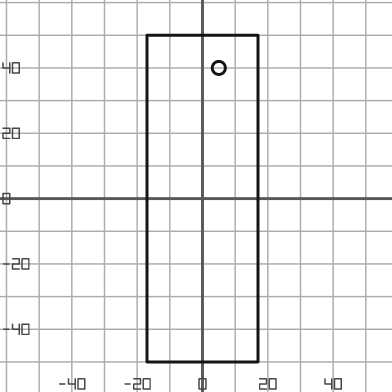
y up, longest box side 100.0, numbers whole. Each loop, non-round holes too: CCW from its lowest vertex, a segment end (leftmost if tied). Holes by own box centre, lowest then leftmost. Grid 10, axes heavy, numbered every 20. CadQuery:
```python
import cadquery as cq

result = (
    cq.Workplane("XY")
    .moveTo(-17.0, -50.0)
    .lineTo(17.0, -50.0)
    .lineTo(17.0, 50.0)
    .lineTo(-17.0, 50.0)
    .close()
    .moveTo(5.0, 40.0)
    .circle(2.0)
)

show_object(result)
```